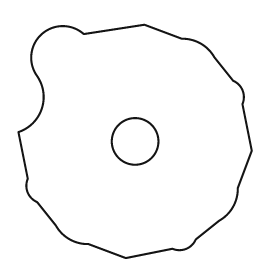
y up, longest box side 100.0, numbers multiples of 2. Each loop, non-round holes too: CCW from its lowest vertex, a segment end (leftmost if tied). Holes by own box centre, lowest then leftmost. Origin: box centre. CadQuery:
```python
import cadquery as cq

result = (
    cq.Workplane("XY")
    .moveTo(-4.0, -50.0)
    .lineTo(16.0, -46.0)
    .threePointArc((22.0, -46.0), (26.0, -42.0))
    .lineTo(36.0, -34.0)
    .threePointArc((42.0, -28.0), (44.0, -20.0))
    .lineTo(50.0, -4.0)
    .lineTo(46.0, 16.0)
    .threePointArc((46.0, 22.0), (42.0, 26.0))
    .lineTo(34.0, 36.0)
    .threePointArc((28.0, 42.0), (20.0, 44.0))
    .lineTo(4.0, 50.0)
    .lineTo(-22.0, 46.0)
    .threePointArc((-40.0, 46.0), (-42.0, 28.0))
    .threePointArc((-40.0, 14.0), (-50.0, 4.0))
    .lineTo(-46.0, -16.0)
    .threePointArc((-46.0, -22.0), (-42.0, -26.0))
    .lineTo(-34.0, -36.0)
    .threePointArc((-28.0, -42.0), (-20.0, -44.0))
    .close()
    .moveTo(0.0, 0.0)
    .circle(10.0)
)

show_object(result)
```